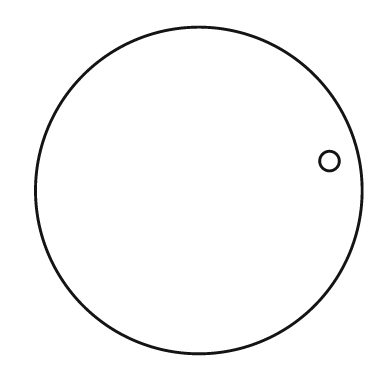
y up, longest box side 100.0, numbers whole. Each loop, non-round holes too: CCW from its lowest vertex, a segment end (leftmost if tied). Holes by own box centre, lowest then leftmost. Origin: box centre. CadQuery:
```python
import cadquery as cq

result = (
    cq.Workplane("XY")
    .moveTo(0.0, 0.0)
    .circle(50.0)
    .moveTo(40.0, 9.0)
    .circle(3.0)
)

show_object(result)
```